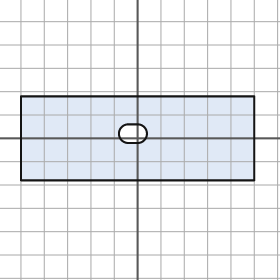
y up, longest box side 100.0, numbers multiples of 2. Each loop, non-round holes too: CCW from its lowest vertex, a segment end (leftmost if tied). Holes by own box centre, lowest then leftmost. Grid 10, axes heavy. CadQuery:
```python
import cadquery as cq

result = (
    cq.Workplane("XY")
    .moveTo(-50.0, -18.0)
    .lineTo(50.0, -18.0)
    .lineTo(50.0, 18.0)
    .lineTo(-50.0, 18.0)
    .close()
    .moveTo(-4.0, -2.0)
    .lineTo(0.0, -2.0)
    .threePointArc((4.0, 2.0), (0.0, 6.0))
    .lineTo(-4.0, 6.0)
    .threePointArc((-8.0, 2.0), (-4.0, -2.0))
    .close()
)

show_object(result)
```